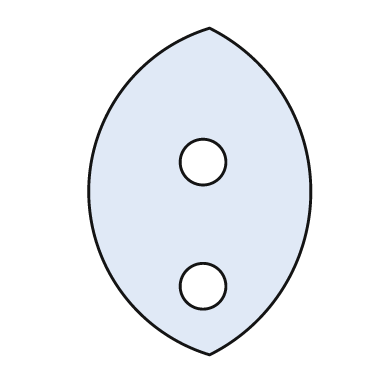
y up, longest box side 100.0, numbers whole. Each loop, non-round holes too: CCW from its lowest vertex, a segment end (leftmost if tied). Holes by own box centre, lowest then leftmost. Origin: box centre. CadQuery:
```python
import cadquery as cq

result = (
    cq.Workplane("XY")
    .moveTo(3.0, -50.0)
    .threePointArc((34.0, 0.0), (3.0, 50.0))
    .threePointArc((-34.0, 0.0), (3.0, -50.0))
    .close()
    .moveTo(1.0, -29.0)
    .circle(7.0)
    .moveTo(1.0, 9.0)
    .circle(7.0)
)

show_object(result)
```